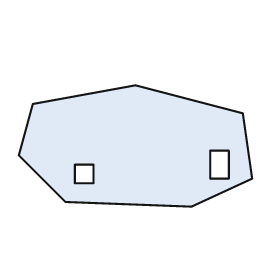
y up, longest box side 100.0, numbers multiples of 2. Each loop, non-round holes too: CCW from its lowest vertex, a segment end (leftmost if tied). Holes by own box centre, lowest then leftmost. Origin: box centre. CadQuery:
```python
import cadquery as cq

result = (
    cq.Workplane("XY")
    .moveTo(24.0, -26.0)
    .lineTo(50.0, -14.0)
    .lineTo(46.0, 14.0)
    .lineTo(0.0, 26.0)
    .lineTo(-44.0, 18.0)
    .lineTo(-50.0, -4.0)
    .lineTo(-30.0, -24.0)
    .close()
    .moveTo(-26.0, -16.0)
    .lineTo(-18.0, -16.0)
    .lineTo(-18.0, -8.0)
    .lineTo(-26.0, -8.0)
    .close()
    .moveTo(32.0, -14.0)
    .lineTo(40.0, -14.0)
    .lineTo(40.0, -2.0)
    .lineTo(32.0, -2.0)
    .close()
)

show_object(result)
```